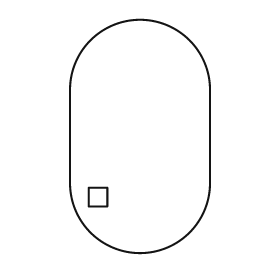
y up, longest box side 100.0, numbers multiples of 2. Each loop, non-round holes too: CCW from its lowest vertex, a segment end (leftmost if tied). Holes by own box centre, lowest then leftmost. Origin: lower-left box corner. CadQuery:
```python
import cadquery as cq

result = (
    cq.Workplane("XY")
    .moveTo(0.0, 30.0)
    .threePointArc((30.0, 0.0), (60.0, 30.0))
    .lineTo(60.0, 70.0)
    .threePointArc((30.0, 100.0), (0.0, 70.0))
    .close()
    .moveTo(8.0, 20.0)
    .lineTo(16.0, 20.0)
    .lineTo(16.0, 28.0)
    .lineTo(8.0, 28.0)
    .close()
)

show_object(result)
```